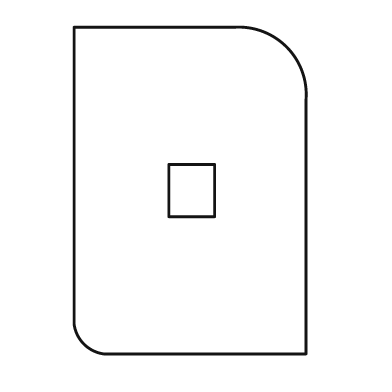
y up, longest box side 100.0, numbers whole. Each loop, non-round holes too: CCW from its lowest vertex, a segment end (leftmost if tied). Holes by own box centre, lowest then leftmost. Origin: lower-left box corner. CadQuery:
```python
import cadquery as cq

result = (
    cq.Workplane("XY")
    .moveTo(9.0, 0.0)
    .lineTo(71.0, 0.0)
    .lineTo(71.0, 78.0)
    .threePointArc((65.0, 94.0), (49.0, 100.0))
    .lineTo(0.0, 100.0)
    .lineTo(0.0, 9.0)
    .threePointArc((3.0, 3.0), (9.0, 0.0))
    .close()
    .moveTo(29.0, 42.0)
    .lineTo(43.0, 42.0)
    .lineTo(43.0, 58.0)
    .lineTo(29.0, 58.0)
    .close()
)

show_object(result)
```